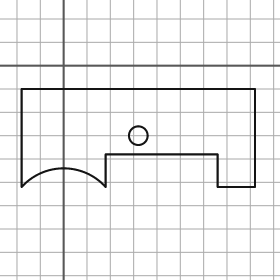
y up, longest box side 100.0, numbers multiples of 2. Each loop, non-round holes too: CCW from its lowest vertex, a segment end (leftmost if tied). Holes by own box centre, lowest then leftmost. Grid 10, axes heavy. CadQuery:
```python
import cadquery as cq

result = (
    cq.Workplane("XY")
    .moveTo(-18.0, -52.0)
    .threePointArc((0.0, -44.0), (18.0, -52.0))
    .lineTo(18.0, -38.0)
    .lineTo(66.0, -38.0)
    .lineTo(66.0, -52.0)
    .lineTo(82.0, -52.0)
    .lineTo(82.0, -10.0)
    .lineTo(-18.0, -10.0)
    .close()
    .moveTo(32.0, -30.0)
    .circle(4.0)
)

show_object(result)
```